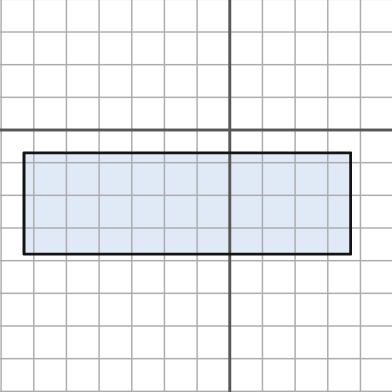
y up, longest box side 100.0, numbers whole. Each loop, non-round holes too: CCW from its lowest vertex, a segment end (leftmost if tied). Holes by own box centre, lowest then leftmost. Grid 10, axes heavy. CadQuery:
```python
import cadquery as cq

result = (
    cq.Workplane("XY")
    .moveTo(-63.0, -38.0)
    .lineTo(37.0, -38.0)
    .lineTo(37.0, -7.0)
    .lineTo(-63.0, -7.0)
    .close()
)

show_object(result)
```